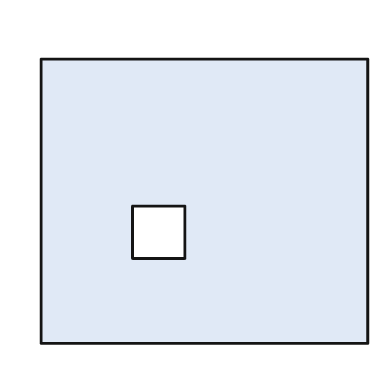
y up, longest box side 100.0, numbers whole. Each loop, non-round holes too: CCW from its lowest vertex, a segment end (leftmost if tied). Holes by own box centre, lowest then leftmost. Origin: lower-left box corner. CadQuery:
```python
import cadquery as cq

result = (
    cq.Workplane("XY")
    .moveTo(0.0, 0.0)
    .lineTo(100.0, 0.0)
    .lineTo(100.0, 87.0)
    .lineTo(0.0, 87.0)
    .close()
    .moveTo(28.0, 26.0)
    .lineTo(44.0, 26.0)
    .lineTo(44.0, 42.0)
    .lineTo(28.0, 42.0)
    .close()
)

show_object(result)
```